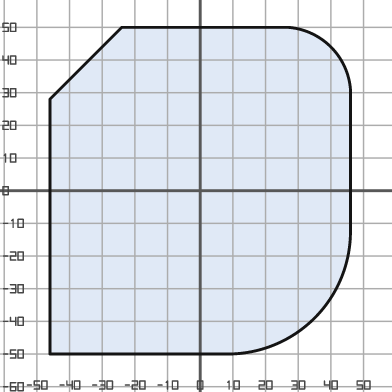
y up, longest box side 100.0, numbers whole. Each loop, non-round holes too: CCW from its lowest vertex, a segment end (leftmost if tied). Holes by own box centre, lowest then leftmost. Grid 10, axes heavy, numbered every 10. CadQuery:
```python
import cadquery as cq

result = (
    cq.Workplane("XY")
    .moveTo(-46.0, -50.0)
    .lineTo(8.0, -50.0)
    .threePointArc((35.0, -39.0), (46.0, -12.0))
    .lineTo(46.0, 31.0)
    .threePointArc((40.0, 44.0), (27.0, 50.0))
    .lineTo(-24.0, 50.0)
    .lineTo(-46.0, 28.0)
    .close()
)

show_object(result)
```